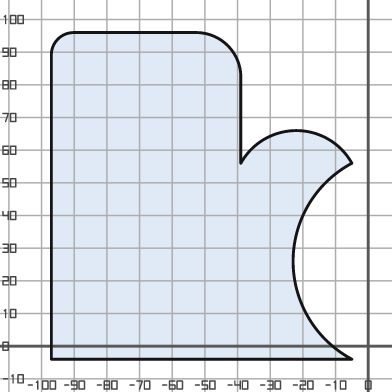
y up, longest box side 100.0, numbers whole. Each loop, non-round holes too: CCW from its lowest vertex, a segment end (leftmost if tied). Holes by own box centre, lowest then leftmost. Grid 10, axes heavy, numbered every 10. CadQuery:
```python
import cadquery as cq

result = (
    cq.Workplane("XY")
    .moveTo(-97.0, -4.0)
    .lineTo(-5.0, -4.0)
    .threePointArc((-23.0, 26.0), (-5.0, 56.0))
    .threePointArc((-22.0, 66.0), (-39.0, 56.0))
    .lineTo(-39.0, 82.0)
    .threePointArc((-43.0, 92.0), (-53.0, 96.0))
    .lineTo(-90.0, 96.0)
    .threePointArc((-95.0, 94.0), (-97.0, 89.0))
    .close()
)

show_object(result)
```